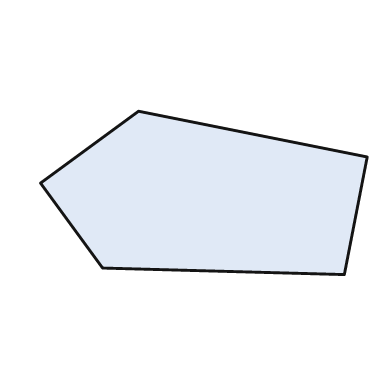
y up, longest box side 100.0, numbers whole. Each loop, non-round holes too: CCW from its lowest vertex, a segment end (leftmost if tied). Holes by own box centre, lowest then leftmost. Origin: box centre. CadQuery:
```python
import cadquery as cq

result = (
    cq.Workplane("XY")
    .moveTo(43.0, -25.0)
    .lineTo(50.0, 11.0)
    .lineTo(-20.0, 25.0)
    .lineTo(-50.0, 3.0)
    .lineTo(-31.0, -23.0)
    .close()
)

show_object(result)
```